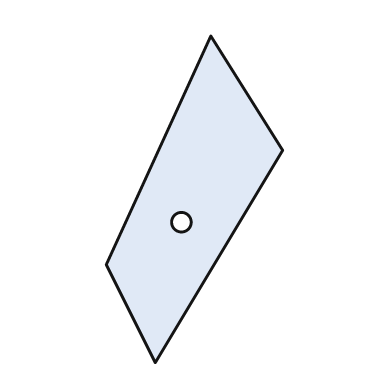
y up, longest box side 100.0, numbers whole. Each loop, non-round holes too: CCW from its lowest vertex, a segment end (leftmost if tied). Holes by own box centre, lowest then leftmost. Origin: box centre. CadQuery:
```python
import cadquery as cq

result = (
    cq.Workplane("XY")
    .moveTo(-12.0, -50.0)
    .lineTo(27.0, 15.0)
    .lineTo(5.0, 50.0)
    .lineTo(-27.0, -20.0)
    .close()
    .moveTo(-4.0, -7.0)
    .circle(3.0)
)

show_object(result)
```